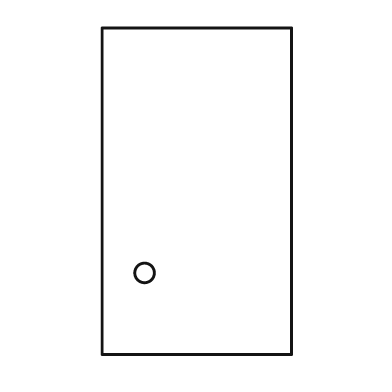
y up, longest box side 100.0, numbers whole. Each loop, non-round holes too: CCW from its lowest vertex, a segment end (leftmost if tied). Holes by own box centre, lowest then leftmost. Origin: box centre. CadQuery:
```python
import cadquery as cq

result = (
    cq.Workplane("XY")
    .moveTo(-29.0, -50.0)
    .lineTo(29.0, -50.0)
    .lineTo(29.0, 50.0)
    .lineTo(-29.0, 50.0)
    .close()
    .moveTo(-16.0, -25.0)
    .circle(3.0)
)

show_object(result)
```